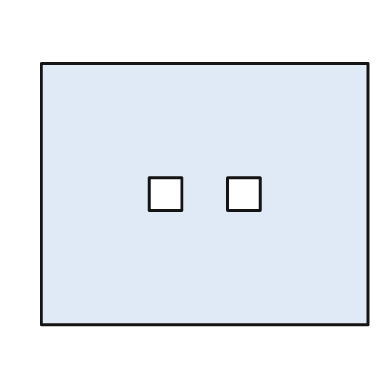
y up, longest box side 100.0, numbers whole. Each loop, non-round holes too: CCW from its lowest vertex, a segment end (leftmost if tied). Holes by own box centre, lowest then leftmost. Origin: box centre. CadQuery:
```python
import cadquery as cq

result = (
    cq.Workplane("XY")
    .moveTo(-50.0, -40.0)
    .lineTo(50.0, -40.0)
    .lineTo(50.0, 40.0)
    .lineTo(-50.0, 40.0)
    .close()
    .moveTo(-17.0, -5.0)
    .lineTo(-7.0, -5.0)
    .lineTo(-7.0, 5.0)
    .lineTo(-17.0, 5.0)
    .close()
    .moveTo(7.0, -5.0)
    .lineTo(17.0, -5.0)
    .lineTo(17.0, 5.0)
    .lineTo(7.0, 5.0)
    .close()
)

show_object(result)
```